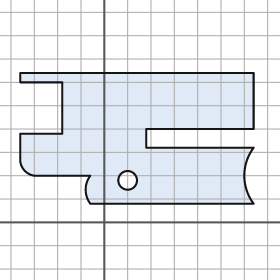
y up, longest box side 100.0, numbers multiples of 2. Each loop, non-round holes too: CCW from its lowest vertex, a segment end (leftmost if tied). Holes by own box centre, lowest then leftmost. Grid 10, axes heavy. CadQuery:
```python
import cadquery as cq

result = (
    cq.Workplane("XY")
    .moveTo(-6.0, 8.0)
    .lineTo(64.0, 8.0)
    .threePointArc((60.0, 20.0), (64.0, 32.0))
    .lineTo(18.0, 32.0)
    .lineTo(18.0, 40.0)
    .lineTo(64.0, 40.0)
    .lineTo(64.0, 64.0)
    .lineTo(-36.0, 64.0)
    .lineTo(-36.0, 60.0)
    .lineTo(-18.0, 60.0)
    .lineTo(-18.0, 38.0)
    .lineTo(-36.0, 38.0)
    .lineTo(-36.0, 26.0)
    .threePointArc((-34.0, 22.0), (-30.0, 20.0))
    .lineTo(-6.0, 20.0)
    .threePointArc((-8.0, 14.0), (-6.0, 8.0))
    .close()
    .moveTo(10.0, 18.0)
    .circle(4.0)
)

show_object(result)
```